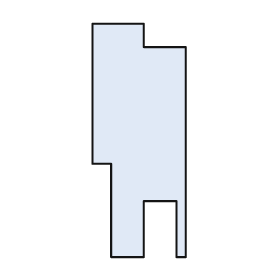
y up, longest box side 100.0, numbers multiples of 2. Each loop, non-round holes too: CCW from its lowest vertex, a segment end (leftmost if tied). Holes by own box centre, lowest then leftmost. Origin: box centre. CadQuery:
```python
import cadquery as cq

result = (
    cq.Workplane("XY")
    .moveTo(-12.0, -50.0)
    .lineTo(2.0, -50.0)
    .lineTo(2.0, -26.0)
    .lineTo(16.0, -26.0)
    .lineTo(16.0, -50.0)
    .lineTo(20.0, -50.0)
    .lineTo(20.0, 40.0)
    .lineTo(2.0, 40.0)
    .lineTo(2.0, 50.0)
    .lineTo(-20.0, 50.0)
    .lineTo(-20.0, -10.0)
    .lineTo(-12.0, -10.0)
    .close()
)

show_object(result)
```